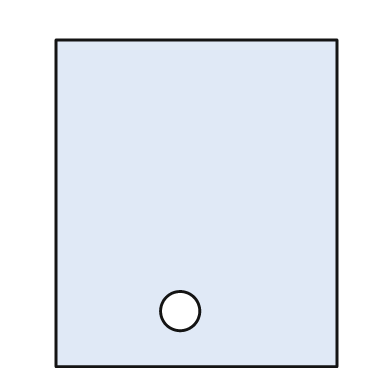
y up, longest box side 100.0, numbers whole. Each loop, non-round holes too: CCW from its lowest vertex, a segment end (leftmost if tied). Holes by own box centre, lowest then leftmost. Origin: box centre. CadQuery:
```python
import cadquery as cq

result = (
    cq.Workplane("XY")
    .moveTo(-43.0, -50.0)
    .lineTo(43.0, -50.0)
    .lineTo(43.0, 50.0)
    .lineTo(-43.0, 50.0)
    .close()
    .moveTo(-5.0, -33.0)
    .circle(6.0)
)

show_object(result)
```